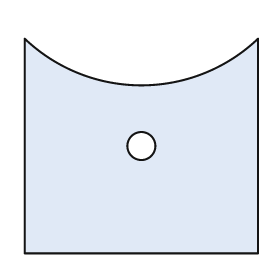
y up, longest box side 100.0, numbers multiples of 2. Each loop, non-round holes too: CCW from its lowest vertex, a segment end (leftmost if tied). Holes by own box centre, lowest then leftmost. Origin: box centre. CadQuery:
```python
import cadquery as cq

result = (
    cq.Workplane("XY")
    .moveTo(-50.0, -46.0)
    .lineTo(50.0, -46.0)
    .lineTo(50.0, 46.0)
    .threePointArc((0.0, 26.0), (-50.0, 46.0))
    .close()
    .moveTo(0.0, 0.0)
    .circle(6.0)
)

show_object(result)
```